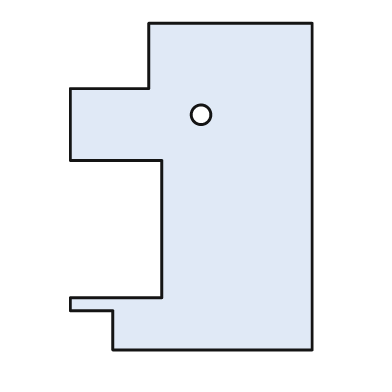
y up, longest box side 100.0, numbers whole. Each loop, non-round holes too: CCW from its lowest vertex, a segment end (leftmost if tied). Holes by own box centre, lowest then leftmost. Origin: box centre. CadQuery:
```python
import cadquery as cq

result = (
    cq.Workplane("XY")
    .moveTo(-24.0, -50.0)
    .lineTo(37.0, -50.0)
    .lineTo(37.0, 50.0)
    .lineTo(-13.0, 50.0)
    .lineTo(-13.0, 30.0)
    .lineTo(-37.0, 30.0)
    .lineTo(-37.0, 8.0)
    .lineTo(-9.0, 8.0)
    .lineTo(-9.0, -34.0)
    .lineTo(-37.0, -34.0)
    .lineTo(-37.0, -38.0)
    .lineTo(-24.0, -38.0)
    .close()
    .moveTo(3.0, 22.0)
    .circle(3.0)
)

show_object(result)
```